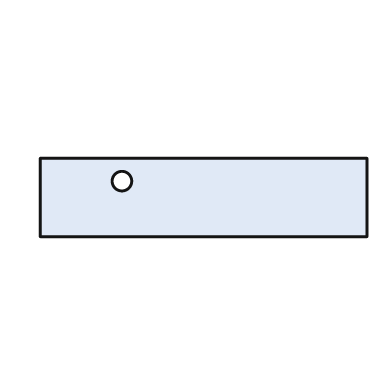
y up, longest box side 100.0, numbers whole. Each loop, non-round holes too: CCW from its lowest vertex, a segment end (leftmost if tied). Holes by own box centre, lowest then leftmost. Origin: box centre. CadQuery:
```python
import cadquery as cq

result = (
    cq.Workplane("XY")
    .moveTo(-50.0, -12.0)
    .lineTo(50.0, -12.0)
    .lineTo(50.0, 12.0)
    .lineTo(-50.0, 12.0)
    .close()
    .moveTo(-25.0, 5.0)
    .circle(3.0)
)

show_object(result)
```